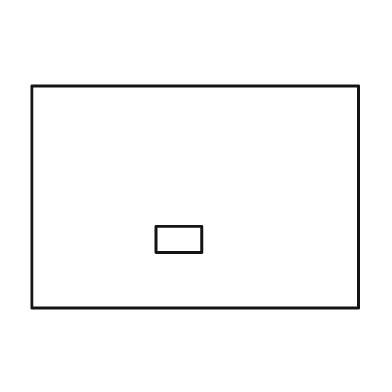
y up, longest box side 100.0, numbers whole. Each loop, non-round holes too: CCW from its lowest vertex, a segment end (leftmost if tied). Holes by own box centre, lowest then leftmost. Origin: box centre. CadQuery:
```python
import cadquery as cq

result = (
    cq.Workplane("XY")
    .moveTo(-50.0, -34.0)
    .lineTo(50.0, -34.0)
    .lineTo(50.0, 34.0)
    .lineTo(-50.0, 34.0)
    .close()
    .moveTo(-12.0, -17.0)
    .lineTo(2.0, -17.0)
    .lineTo(2.0, -9.0)
    .lineTo(-12.0, -9.0)
    .close()
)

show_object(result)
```